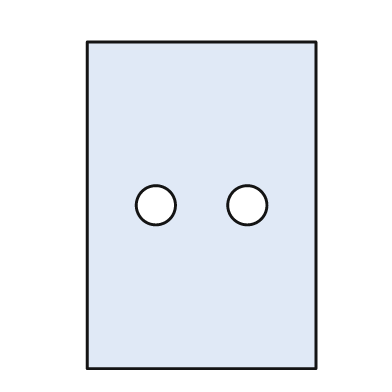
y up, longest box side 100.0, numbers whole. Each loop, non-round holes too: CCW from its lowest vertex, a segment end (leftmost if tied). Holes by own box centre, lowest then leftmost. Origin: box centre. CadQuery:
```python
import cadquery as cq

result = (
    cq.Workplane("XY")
    .moveTo(-35.0, -50.0)
    .lineTo(35.0, -50.0)
    .lineTo(35.0, 50.0)
    .lineTo(-35.0, 50.0)
    .close()
    .moveTo(-14.0, 0.0)
    .circle(6.0)
    .moveTo(14.0, 0.0)
    .circle(6.0)
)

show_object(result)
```